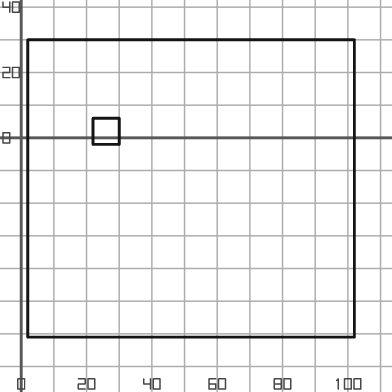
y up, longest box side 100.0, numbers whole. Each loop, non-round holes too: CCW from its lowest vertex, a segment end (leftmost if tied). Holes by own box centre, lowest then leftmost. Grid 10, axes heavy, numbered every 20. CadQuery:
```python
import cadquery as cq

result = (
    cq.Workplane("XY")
    .moveTo(2.0, -61.0)
    .lineTo(102.0, -61.0)
    .lineTo(102.0, 30.0)
    .lineTo(2.0, 30.0)
    .close()
    .moveTo(22.0, -2.0)
    .lineTo(30.0, -2.0)
    .lineTo(30.0, 6.0)
    .lineTo(22.0, 6.0)
    .close()
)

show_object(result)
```